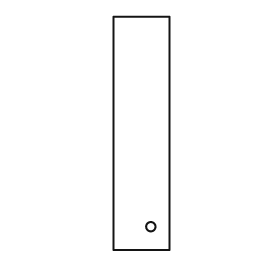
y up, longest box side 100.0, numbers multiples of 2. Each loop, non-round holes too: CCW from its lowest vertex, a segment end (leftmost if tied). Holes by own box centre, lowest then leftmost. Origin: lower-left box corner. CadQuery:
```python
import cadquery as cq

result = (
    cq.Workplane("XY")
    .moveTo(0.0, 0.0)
    .lineTo(24.0, 0.0)
    .lineTo(24.0, 100.0)
    .lineTo(0.0, 100.0)
    .close()
    .moveTo(16.0, 10.0)
    .circle(2.0)
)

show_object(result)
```